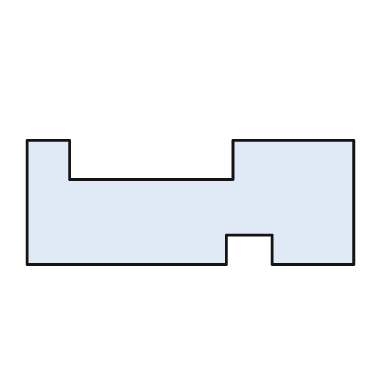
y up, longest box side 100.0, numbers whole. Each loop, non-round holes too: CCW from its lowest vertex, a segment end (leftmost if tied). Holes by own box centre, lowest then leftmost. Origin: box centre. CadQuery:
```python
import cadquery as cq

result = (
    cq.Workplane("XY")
    .moveTo(-50.0, -19.0)
    .lineTo(11.0, -19.0)
    .lineTo(11.0, -10.0)
    .lineTo(25.0, -10.0)
    .lineTo(25.0, -19.0)
    .lineTo(50.0, -19.0)
    .lineTo(50.0, 19.0)
    .lineTo(13.0, 19.0)
    .lineTo(13.0, 7.0)
    .lineTo(-37.0, 7.0)
    .lineTo(-37.0, 19.0)
    .lineTo(-50.0, 19.0)
    .close()
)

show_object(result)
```